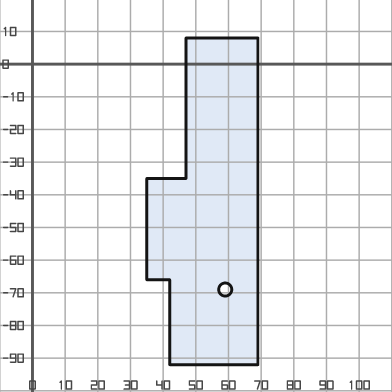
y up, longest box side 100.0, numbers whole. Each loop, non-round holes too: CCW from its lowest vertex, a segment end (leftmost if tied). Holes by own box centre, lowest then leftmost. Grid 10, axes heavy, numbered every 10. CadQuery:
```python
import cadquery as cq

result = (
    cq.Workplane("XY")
    .moveTo(42.0, -92.0)
    .lineTo(69.0, -92.0)
    .lineTo(69.0, 8.0)
    .lineTo(47.0, 8.0)
    .lineTo(47.0, -35.0)
    .lineTo(35.0, -35.0)
    .lineTo(35.0, -66.0)
    .lineTo(42.0, -66.0)
    .close()
    .moveTo(59.0, -69.0)
    .circle(2.0)
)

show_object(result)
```